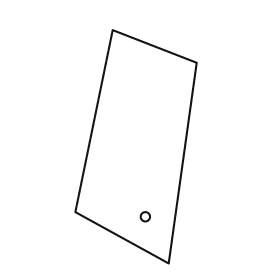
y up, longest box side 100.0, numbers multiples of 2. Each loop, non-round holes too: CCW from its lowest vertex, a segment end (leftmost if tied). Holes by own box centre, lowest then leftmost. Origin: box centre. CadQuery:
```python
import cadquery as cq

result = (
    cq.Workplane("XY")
    .moveTo(14.0, -50.0)
    .lineTo(26.0, 36.0)
    .lineTo(-10.0, 50.0)
    .lineTo(-26.0, -28.0)
    .close()
    .moveTo(4.0, -30.0)
    .circle(2.0)
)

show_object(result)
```